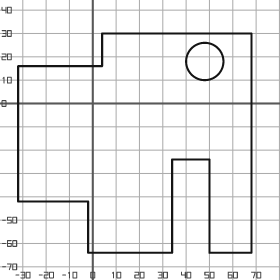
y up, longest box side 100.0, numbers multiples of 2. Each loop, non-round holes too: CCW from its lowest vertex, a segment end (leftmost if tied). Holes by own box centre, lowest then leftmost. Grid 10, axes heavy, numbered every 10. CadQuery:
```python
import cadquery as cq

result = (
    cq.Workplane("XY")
    .moveTo(-2.0, -64.0)
    .lineTo(34.0, -64.0)
    .lineTo(34.0, -24.0)
    .lineTo(50.0, -24.0)
    .lineTo(50.0, -64.0)
    .lineTo(68.0, -64.0)
    .lineTo(68.0, 30.0)
    .lineTo(4.0, 30.0)
    .lineTo(4.0, 16.0)
    .lineTo(-32.0, 16.0)
    .lineTo(-32.0, -42.0)
    .lineTo(-2.0, -42.0)
    .close()
    .moveTo(48.0, 18.0)
    .circle(8.0)
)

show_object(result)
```